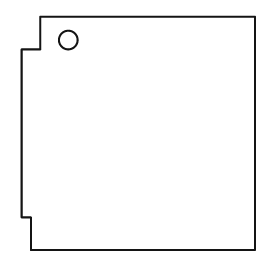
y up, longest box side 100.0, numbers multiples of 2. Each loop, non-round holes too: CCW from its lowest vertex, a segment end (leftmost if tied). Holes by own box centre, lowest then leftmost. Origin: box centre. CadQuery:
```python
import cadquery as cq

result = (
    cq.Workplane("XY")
    .moveTo(-46.0, -50.0)
    .lineTo(50.0, -50.0)
    .lineTo(50.0, 50.0)
    .lineTo(-42.0, 50.0)
    .lineTo(-42.0, 36.0)
    .lineTo(-50.0, 36.0)
    .lineTo(-50.0, -36.0)
    .lineTo(-46.0, -36.0)
    .close()
    .moveTo(-30.0, 40.0)
    .circle(4.0)
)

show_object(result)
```